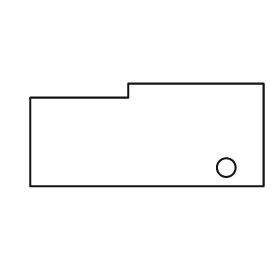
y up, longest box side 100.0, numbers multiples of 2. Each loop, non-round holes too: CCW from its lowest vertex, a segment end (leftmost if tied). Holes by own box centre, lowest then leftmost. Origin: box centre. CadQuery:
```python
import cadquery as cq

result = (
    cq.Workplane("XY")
    .moveTo(-50.0, -22.0)
    .lineTo(50.0, -22.0)
    .lineTo(50.0, 22.0)
    .lineTo(-8.0, 22.0)
    .lineTo(-8.0, 16.0)
    .lineTo(-50.0, 16.0)
    .close()
    .moveTo(34.0, -14.0)
    .circle(4.0)
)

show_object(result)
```